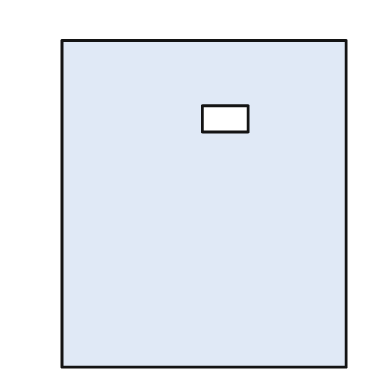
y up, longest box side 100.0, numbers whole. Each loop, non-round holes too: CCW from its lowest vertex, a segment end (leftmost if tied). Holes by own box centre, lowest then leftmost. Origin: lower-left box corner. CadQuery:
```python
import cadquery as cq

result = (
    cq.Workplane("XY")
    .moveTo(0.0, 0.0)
    .lineTo(87.0, 0.0)
    .lineTo(87.0, 100.0)
    .lineTo(0.0, 100.0)
    .close()
    .moveTo(43.0, 72.0)
    .lineTo(57.0, 72.0)
    .lineTo(57.0, 80.0)
    .lineTo(43.0, 80.0)
    .close()
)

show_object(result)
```